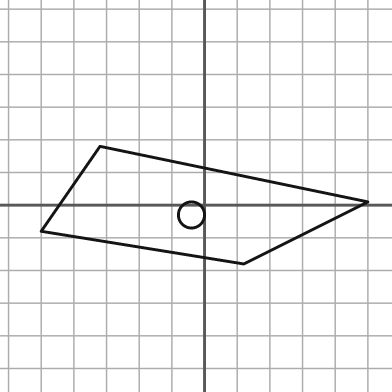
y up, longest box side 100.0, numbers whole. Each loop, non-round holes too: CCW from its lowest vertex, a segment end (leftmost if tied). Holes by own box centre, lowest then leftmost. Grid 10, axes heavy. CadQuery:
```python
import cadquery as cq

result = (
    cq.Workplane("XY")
    .moveTo(12.0, -18.0)
    .lineTo(50.0, 1.0)
    .lineTo(-32.0, 18.0)
    .lineTo(-50.0, -8.0)
    .close()
    .moveTo(-4.0, -3.0)
    .circle(4.0)
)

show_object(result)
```